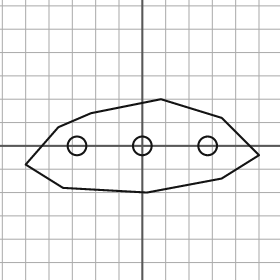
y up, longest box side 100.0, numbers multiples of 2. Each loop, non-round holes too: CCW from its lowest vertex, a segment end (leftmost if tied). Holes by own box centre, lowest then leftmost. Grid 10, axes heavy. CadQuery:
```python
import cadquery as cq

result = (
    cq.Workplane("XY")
    .moveTo(2.0, -20.0)
    .lineTo(34.0, -14.0)
    .lineTo(50.0, -4.0)
    .lineTo(34.0, 12.0)
    .lineTo(8.0, 20.0)
    .lineTo(-22.0, 14.0)
    .lineTo(-36.0, 8.0)
    .lineTo(-50.0, -8.0)
    .lineTo(-34.0, -18.0)
    .close()
    .moveTo(-28.0, 0.0)
    .circle(4.0)
    .moveTo(0.0, 0.0)
    .circle(4.0)
    .moveTo(28.0, 0.0)
    .circle(4.0)
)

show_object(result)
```